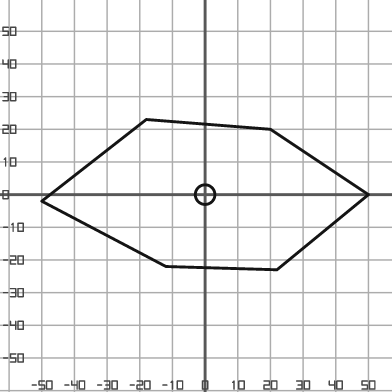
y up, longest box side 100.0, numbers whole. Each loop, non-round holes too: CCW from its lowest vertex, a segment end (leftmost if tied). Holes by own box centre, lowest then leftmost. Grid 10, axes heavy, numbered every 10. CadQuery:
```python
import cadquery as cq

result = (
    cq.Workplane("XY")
    .moveTo(22.0, -23.0)
    .lineTo(50.0, 0.0)
    .lineTo(20.0, 20.0)
    .lineTo(-18.0, 23.0)
    .lineTo(-50.0, -2.0)
    .lineTo(-12.0, -22.0)
    .close()
    .moveTo(0.0, 0.0)
    .circle(3.0)
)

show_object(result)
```